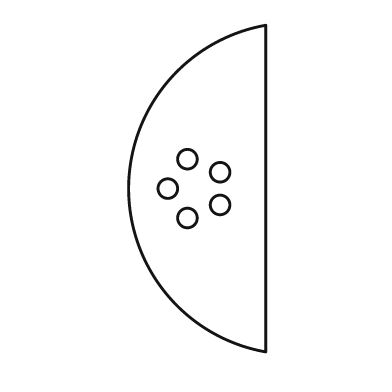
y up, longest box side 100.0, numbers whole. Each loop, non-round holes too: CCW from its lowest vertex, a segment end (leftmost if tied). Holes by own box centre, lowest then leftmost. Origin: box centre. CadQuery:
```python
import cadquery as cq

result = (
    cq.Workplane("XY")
    .moveTo(21.0, -50.0)
    .lineTo(21.0, 50.0)
    .threePointArc((-21.0, 0.0), (21.0, -50.0))
    .close()
    .moveTo(-3.0, -9.0)
    .circle(3.0)
    .moveTo(7.0, -5.0)
    .circle(3.0)
    .moveTo(-9.0, 0.0)
    .circle(3.0)
    .moveTo(7.0, 5.0)
    .circle(3.0)
    .moveTo(-3.0, 9.0)
    .circle(3.0)
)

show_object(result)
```